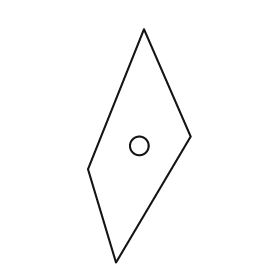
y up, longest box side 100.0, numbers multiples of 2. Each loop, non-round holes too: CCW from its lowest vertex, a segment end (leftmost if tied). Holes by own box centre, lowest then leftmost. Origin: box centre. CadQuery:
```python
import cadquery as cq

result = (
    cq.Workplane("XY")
    .moveTo(-10.0, -50.0)
    .lineTo(22.0, 4.0)
    .lineTo(2.0, 50.0)
    .lineTo(-22.0, -10.0)
    .close()
    .moveTo(0.0, 0.0)
    .circle(4.0)
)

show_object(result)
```